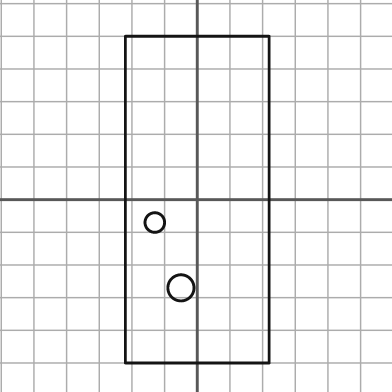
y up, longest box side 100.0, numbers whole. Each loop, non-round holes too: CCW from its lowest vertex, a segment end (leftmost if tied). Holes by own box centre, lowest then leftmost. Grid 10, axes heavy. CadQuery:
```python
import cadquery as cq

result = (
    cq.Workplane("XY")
    .moveTo(-22.0, -50.0)
    .lineTo(22.0, -50.0)
    .lineTo(22.0, 50.0)
    .lineTo(-22.0, 50.0)
    .close()
    .moveTo(-5.0, -27.0)
    .circle(4.0)
    .moveTo(-13.0, -7.0)
    .circle(3.0)
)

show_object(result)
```